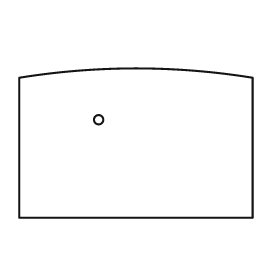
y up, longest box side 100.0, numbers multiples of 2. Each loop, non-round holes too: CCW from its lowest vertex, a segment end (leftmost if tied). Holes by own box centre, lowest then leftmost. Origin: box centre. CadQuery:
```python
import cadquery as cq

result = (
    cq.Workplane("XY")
    .moveTo(-50.0, -32.0)
    .lineTo(50.0, -32.0)
    .lineTo(50.0, 28.0)
    .threePointArc((0.0, 32.0), (-50.0, 28.0))
    .close()
    .moveTo(-16.0, 10.0)
    .circle(2.0)
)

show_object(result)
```